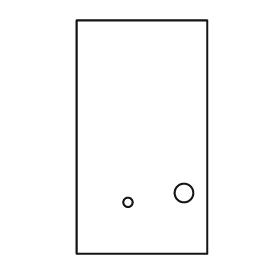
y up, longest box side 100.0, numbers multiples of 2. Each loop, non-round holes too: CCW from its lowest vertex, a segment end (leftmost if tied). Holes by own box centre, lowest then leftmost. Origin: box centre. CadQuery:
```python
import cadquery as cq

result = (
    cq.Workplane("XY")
    .moveTo(-28.0, -50.0)
    .lineTo(28.0, -50.0)
    .lineTo(28.0, 50.0)
    .lineTo(-28.0, 50.0)
    .close()
    .moveTo(-6.0, -28.0)
    .circle(2.0)
    .moveTo(18.0, -24.0)
    .circle(4.0)
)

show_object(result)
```